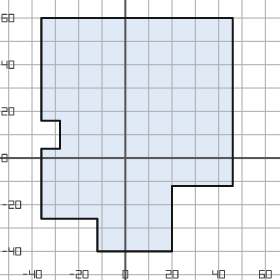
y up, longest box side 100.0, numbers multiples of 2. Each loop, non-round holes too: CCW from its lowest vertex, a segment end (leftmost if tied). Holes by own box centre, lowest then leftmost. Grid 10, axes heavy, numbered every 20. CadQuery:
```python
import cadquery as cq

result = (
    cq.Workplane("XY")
    .moveTo(-12.0, -40.0)
    .lineTo(20.0, -40.0)
    .lineTo(20.0, -12.0)
    .lineTo(46.0, -12.0)
    .lineTo(46.0, 60.0)
    .lineTo(-36.0, 60.0)
    .lineTo(-36.0, 16.0)
    .lineTo(-28.0, 16.0)
    .lineTo(-28.0, 4.0)
    .lineTo(-36.0, 4.0)
    .lineTo(-36.0, -26.0)
    .lineTo(-12.0, -26.0)
    .close()
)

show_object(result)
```